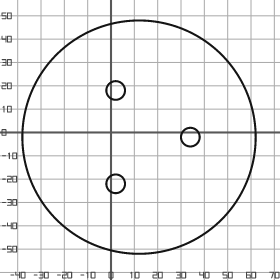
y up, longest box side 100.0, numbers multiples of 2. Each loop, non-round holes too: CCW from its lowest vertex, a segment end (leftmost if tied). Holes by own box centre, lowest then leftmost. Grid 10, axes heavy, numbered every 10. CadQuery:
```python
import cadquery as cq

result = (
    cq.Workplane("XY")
    .moveTo(12.0, -2.0)
    .circle(50.0)
    .moveTo(2.0, -22.0)
    .circle(4.0)
    .moveTo(34.0, -2.0)
    .circle(4.0)
    .moveTo(2.0, 18.0)
    .circle(4.0)
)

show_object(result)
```